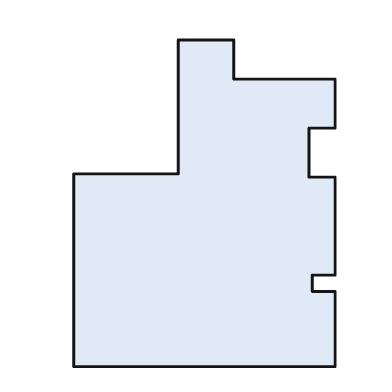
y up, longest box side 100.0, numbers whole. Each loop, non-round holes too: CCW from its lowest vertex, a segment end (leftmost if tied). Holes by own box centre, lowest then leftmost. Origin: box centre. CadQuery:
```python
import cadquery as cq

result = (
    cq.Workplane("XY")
    .moveTo(-40.0, -50.0)
    .lineTo(40.0, -50.0)
    .lineTo(40.0, -27.0)
    .lineTo(33.0, -27.0)
    .lineTo(33.0, -22.0)
    .lineTo(40.0, -22.0)
    .lineTo(40.0, 8.0)
    .lineTo(32.0, 8.0)
    .lineTo(32.0, 23.0)
    .lineTo(40.0, 23.0)
    .lineTo(40.0, 38.0)
    .lineTo(9.0, 38.0)
    .lineTo(9.0, 50.0)
    .lineTo(-8.0, 50.0)
    .lineTo(-8.0, 9.0)
    .lineTo(-40.0, 9.0)
    .close()
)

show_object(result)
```